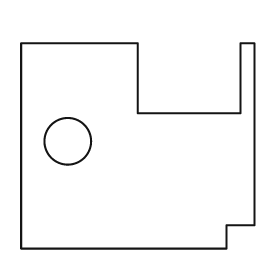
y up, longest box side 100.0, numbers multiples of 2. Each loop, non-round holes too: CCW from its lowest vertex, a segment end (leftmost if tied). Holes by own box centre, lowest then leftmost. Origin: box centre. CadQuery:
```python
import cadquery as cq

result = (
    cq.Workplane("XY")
    .moveTo(-50.0, -44.0)
    .lineTo(38.0, -44.0)
    .lineTo(38.0, -34.0)
    .lineTo(50.0, -34.0)
    .lineTo(50.0, 44.0)
    .lineTo(44.0, 44.0)
    .lineTo(44.0, 14.0)
    .lineTo(0.0, 14.0)
    .lineTo(0.0, 44.0)
    .lineTo(-50.0, 44.0)
    .close()
    .moveTo(-30.0, 2.0)
    .circle(10.0)
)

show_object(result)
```